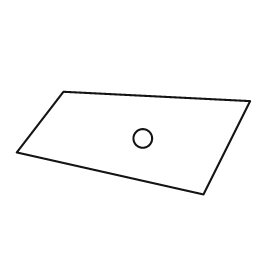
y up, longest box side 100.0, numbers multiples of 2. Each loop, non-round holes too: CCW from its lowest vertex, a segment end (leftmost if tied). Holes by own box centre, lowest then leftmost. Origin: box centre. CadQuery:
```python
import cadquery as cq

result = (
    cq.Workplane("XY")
    .moveTo(30.0, -22.0)
    .lineTo(50.0, 18.0)
    .lineTo(-30.0, 22.0)
    .lineTo(-50.0, -4.0)
    .close()
    .moveTo(4.0, 2.0)
    .circle(4.0)
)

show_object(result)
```